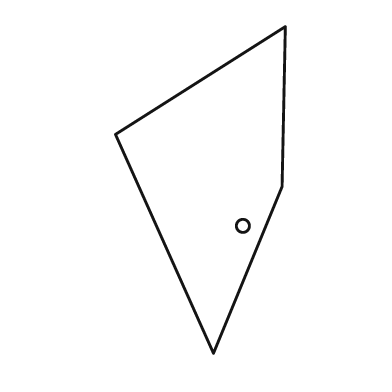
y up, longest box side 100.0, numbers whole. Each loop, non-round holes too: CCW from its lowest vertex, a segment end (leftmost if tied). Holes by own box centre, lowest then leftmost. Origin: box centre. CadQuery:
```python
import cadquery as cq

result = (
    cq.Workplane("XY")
    .moveTo(4.0, -50.0)
    .lineTo(25.0, 1.0)
    .lineTo(26.0, 50.0)
    .lineTo(-26.0, 17.0)
    .close()
    .moveTo(13.0, -11.0)
    .circle(2.0)
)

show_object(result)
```